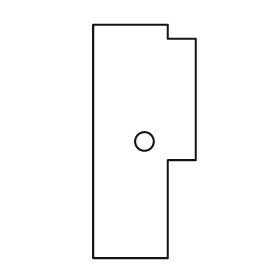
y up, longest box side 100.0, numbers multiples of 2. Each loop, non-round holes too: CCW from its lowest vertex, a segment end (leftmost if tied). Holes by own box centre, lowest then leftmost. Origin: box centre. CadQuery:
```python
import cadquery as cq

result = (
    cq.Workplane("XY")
    .moveTo(-22.0, -50.0)
    .lineTo(10.0, -50.0)
    .lineTo(10.0, -8.0)
    .lineTo(22.0, -8.0)
    .lineTo(22.0, 44.0)
    .lineTo(10.0, 44.0)
    .lineTo(10.0, 50.0)
    .lineTo(-22.0, 50.0)
    .close()
    .moveTo(0.0, 0.0)
    .circle(4.0)
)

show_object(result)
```